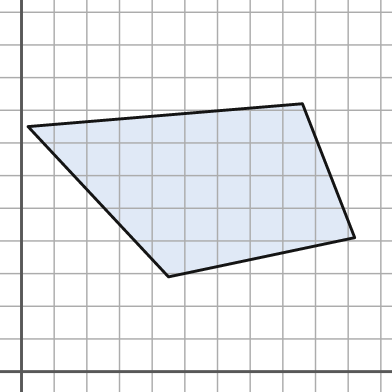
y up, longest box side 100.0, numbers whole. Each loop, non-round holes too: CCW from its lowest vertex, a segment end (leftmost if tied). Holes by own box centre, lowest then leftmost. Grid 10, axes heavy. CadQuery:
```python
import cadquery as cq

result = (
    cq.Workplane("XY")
    .moveTo(45.0, 29.0)
    .lineTo(102.0, 41.0)
    .lineTo(86.0, 82.0)
    .lineTo(2.0, 75.0)
    .close()
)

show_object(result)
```